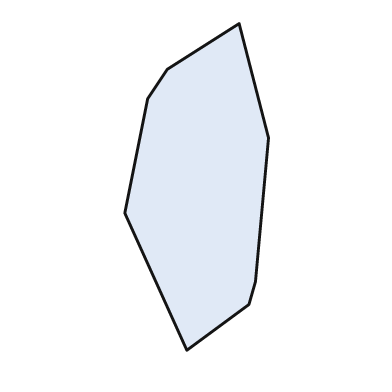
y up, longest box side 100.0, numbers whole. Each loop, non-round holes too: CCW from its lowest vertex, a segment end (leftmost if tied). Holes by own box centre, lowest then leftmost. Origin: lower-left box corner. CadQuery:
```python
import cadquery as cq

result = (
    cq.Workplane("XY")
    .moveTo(19.0, 0.0)
    .lineTo(38.0, 14.0)
    .lineTo(40.0, 21.0)
    .lineTo(44.0, 65.0)
    .lineTo(35.0, 100.0)
    .lineTo(13.0, 86.0)
    .lineTo(7.0, 77.0)
    .lineTo(0.0, 42.0)
    .close()
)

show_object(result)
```